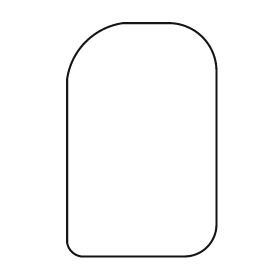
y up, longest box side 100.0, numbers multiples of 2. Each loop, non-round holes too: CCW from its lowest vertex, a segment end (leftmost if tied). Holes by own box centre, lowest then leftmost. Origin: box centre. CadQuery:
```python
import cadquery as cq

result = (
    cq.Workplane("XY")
    .moveTo(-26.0, -50.0)
    .lineTo(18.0, -50.0)
    .threePointArc((28.0, -46.0), (32.0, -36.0))
    .lineTo(32.0, 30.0)
    .threePointArc((26.0, 44.0), (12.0, 50.0))
    .lineTo(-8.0, 50.0)
    .threePointArc((-24.0, 42.0), (-32.0, 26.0))
    .lineTo(-32.0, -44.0)
    .threePointArc((-30.0, -48.0), (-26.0, -50.0))
    .close()
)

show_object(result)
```